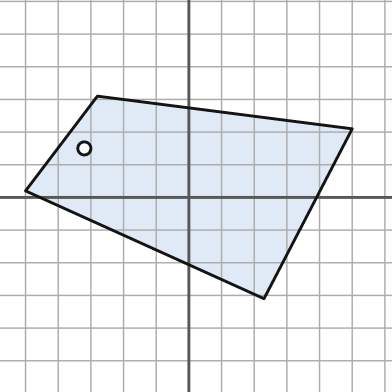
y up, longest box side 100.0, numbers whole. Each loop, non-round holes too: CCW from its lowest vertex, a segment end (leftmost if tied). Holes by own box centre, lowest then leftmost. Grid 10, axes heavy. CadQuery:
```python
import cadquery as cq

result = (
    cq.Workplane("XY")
    .moveTo(23.0, -31.0)
    .lineTo(50.0, 21.0)
    .lineTo(-28.0, 31.0)
    .lineTo(-50.0, 2.0)
    .close()
    .moveTo(-32.0, 15.0)
    .circle(2.0)
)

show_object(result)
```